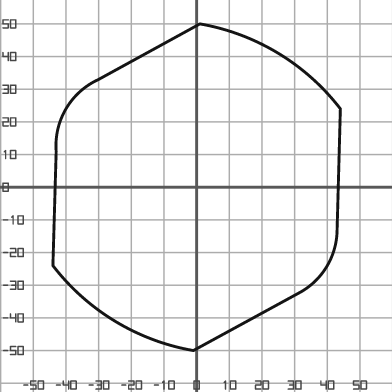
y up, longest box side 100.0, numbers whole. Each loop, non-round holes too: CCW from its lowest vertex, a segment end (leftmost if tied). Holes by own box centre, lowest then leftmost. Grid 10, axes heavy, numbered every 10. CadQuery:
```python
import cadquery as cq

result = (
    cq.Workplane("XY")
    .moveTo(-1.0, -50.0)
    .lineTo(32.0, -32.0)
    .threePointArc((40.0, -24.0), (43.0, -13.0))
    .lineTo(44.0, 24.0)
    .threePointArc((25.0, 41.0), (1.0, 50.0))
    .lineTo(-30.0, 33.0)
    .threePointArc((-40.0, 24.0), (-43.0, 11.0))
    .lineTo(-44.0, -24.0)
    .threePointArc((-25.0, -41.0), (-1.0, -50.0))
    .close()
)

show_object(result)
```